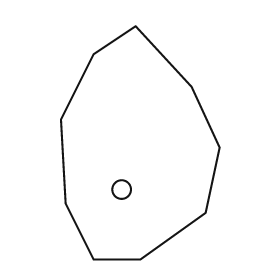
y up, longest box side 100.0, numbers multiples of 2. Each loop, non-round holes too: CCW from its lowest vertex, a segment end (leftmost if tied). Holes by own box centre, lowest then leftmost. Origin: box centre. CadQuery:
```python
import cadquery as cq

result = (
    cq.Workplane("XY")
    .moveTo(-20.0, -50.0)
    .lineTo(0.0, -50.0)
    .lineTo(28.0, -30.0)
    .lineTo(34.0, -2.0)
    .lineTo(22.0, 24.0)
    .lineTo(-2.0, 50.0)
    .lineTo(-20.0, 38.0)
    .lineTo(-34.0, 10.0)
    .lineTo(-32.0, -26.0)
    .close()
    .moveTo(-8.0, -20.0)
    .circle(4.0)
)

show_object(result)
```